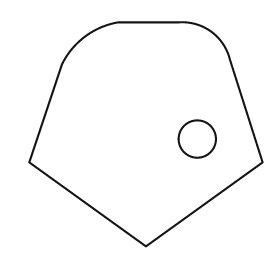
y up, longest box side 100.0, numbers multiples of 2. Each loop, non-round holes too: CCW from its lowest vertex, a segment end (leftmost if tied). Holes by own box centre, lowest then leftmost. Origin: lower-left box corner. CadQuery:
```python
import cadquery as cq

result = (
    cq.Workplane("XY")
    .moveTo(50.0, 0.0)
    .lineTo(100.0, 36.0)
    .lineTo(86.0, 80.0)
    .threePointArc((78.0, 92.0), (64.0, 96.0))
    .lineTo(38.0, 96.0)
    .threePointArc((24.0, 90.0), (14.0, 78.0))
    .lineTo(0.0, 36.0)
    .close()
    .moveTo(72.0, 46.0)
    .circle(8.0)
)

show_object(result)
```